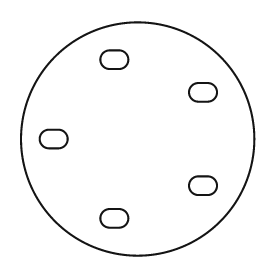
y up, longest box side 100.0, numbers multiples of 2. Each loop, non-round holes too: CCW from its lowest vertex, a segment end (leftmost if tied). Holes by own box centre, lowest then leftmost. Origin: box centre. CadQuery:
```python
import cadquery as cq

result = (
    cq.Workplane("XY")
    .moveTo(0.0, 0.0)
    .circle(50.0)
    .moveTo(-12.0, -38.0)
    .lineTo(-8.0, -38.0)
    .threePointArc((-4.0, -34.0), (-8.0, -30.0))
    .lineTo(-12.0, -30.0)
    .threePointArc((-16.0, -34.0), (-12.0, -38.0))
    .close()
    .moveTo(26.0, -24.0)
    .lineTo(30.0, -24.0)
    .threePointArc((34.0, -20.0), (30.0, -16.0))
    .lineTo(26.0, -16.0)
    .threePointArc((22.0, -20.0), (26.0, -24.0))
    .close()
    .moveTo(-38.0, -4.0)
    .lineTo(-34.0, -4.0)
    .threePointArc((-30.0, 0.0), (-34.0, 4.0))
    .lineTo(-38.0, 4.0)
    .threePointArc((-42.0, 0.0), (-38.0, -4.0))
    .close()
    .moveTo(26.0, 16.0)
    .lineTo(30.0, 16.0)
    .threePointArc((34.0, 20.0), (30.0, 24.0))
    .lineTo(26.0, 24.0)
    .threePointArc((22.0, 20.0), (26.0, 16.0))
    .close()
    .moveTo(-12.0, 30.0)
    .lineTo(-8.0, 30.0)
    .threePointArc((-4.0, 34.0), (-8.0, 38.0))
    .lineTo(-12.0, 38.0)
    .threePointArc((-16.0, 34.0), (-12.0, 30.0))
    .close()
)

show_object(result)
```